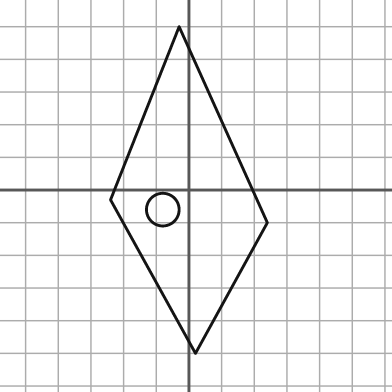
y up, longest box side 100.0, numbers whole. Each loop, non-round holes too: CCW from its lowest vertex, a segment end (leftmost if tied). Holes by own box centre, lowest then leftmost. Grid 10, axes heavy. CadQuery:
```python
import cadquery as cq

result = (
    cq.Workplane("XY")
    .moveTo(2.0, -50.0)
    .lineTo(24.0, -10.0)
    .lineTo(-3.0, 50.0)
    .lineTo(-24.0, -3.0)
    .close()
    .moveTo(-8.0, -6.0)
    .circle(5.0)
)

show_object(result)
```